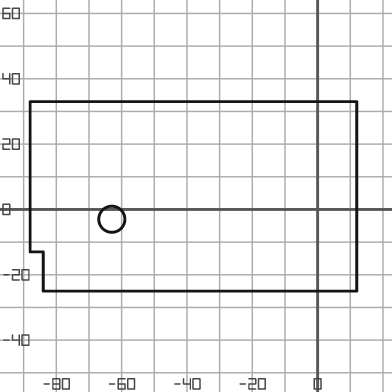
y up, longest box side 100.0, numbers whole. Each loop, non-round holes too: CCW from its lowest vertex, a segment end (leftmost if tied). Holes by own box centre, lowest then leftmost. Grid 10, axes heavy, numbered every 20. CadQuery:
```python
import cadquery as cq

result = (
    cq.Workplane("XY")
    .moveTo(-84.0, -25.0)
    .lineTo(12.0, -25.0)
    .lineTo(12.0, 33.0)
    .lineTo(-88.0, 33.0)
    .lineTo(-88.0, -13.0)
    .lineTo(-84.0, -13.0)
    .close()
    .moveTo(-63.0, -3.0)
    .circle(4.0)
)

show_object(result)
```